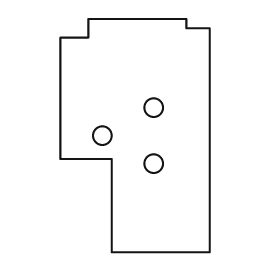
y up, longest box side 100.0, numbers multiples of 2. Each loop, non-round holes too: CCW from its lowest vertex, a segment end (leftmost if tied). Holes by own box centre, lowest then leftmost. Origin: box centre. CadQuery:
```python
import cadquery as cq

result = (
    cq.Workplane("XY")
    .moveTo(-10.0, -50.0)
    .lineTo(32.0, -50.0)
    .lineTo(32.0, 46.0)
    .lineTo(22.0, 46.0)
    .lineTo(22.0, 50.0)
    .lineTo(-20.0, 50.0)
    .lineTo(-20.0, 42.0)
    .lineTo(-32.0, 42.0)
    .lineTo(-32.0, -10.0)
    .lineTo(-10.0, -10.0)
    .close()
    .moveTo(8.0, -12.0)
    .circle(4.0)
    .moveTo(-14.0, 0.0)
    .circle(4.0)
    .moveTo(8.0, 12.0)
    .circle(4.0)
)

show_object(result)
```